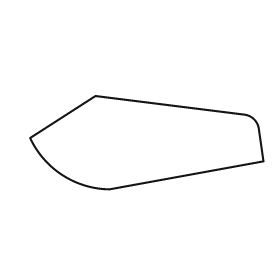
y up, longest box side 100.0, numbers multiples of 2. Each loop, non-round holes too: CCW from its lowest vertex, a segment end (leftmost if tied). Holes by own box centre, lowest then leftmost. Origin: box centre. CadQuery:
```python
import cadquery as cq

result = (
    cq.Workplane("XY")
    .moveTo(-16.0, -20.0)
    .lineTo(50.0, -8.0)
    .lineTo(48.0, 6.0)
    .threePointArc((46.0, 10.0), (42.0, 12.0))
    .lineTo(-22.0, 20.0)
    .lineTo(-50.0, 2.0)
    .threePointArc((-36.0, -14.0), (-16.0, -20.0))
    .close()
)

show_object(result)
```